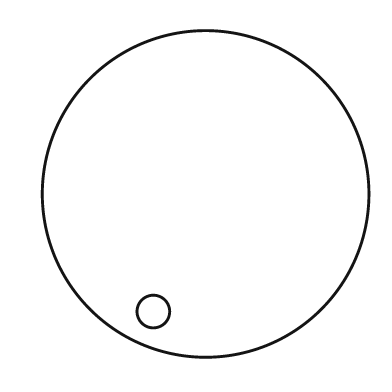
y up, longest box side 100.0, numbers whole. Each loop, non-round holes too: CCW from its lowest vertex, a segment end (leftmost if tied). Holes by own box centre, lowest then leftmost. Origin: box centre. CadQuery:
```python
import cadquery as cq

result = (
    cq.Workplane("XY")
    .moveTo(0.0, 0.0)
    .circle(50.0)
    .moveTo(-16.0, -36.0)
    .circle(5.0)
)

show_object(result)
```